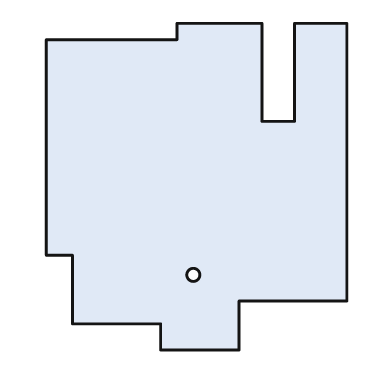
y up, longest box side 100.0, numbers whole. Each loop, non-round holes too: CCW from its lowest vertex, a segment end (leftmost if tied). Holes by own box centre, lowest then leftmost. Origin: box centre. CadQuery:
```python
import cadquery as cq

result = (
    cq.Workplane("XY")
    .moveTo(-11.0, -50.0)
    .lineTo(13.0, -50.0)
    .lineTo(13.0, -35.0)
    .lineTo(46.0, -35.0)
    .lineTo(46.0, 50.0)
    .lineTo(30.0, 50.0)
    .lineTo(30.0, 20.0)
    .lineTo(20.0, 20.0)
    .lineTo(20.0, 50.0)
    .lineTo(-6.0, 50.0)
    .lineTo(-6.0, 45.0)
    .lineTo(-46.0, 45.0)
    .lineTo(-46.0, -21.0)
    .lineTo(-38.0, -21.0)
    .lineTo(-38.0, -42.0)
    .lineTo(-11.0, -42.0)
    .close()
    .moveTo(-1.0, -27.0)
    .circle(2.0)
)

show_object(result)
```